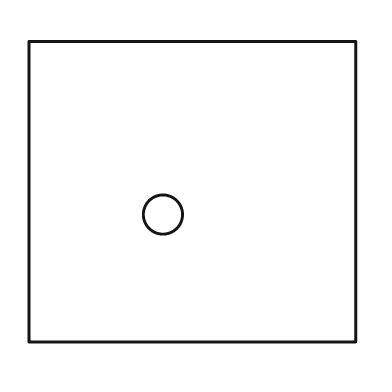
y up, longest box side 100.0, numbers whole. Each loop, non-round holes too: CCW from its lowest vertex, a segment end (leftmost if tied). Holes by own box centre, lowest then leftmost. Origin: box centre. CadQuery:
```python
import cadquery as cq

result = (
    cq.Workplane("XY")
    .moveTo(-50.0, -46.0)
    .lineTo(50.0, -46.0)
    .lineTo(50.0, 46.0)
    .lineTo(-50.0, 46.0)
    .close()
    .moveTo(-9.0, -7.0)
    .circle(6.0)
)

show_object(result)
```